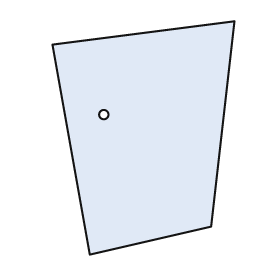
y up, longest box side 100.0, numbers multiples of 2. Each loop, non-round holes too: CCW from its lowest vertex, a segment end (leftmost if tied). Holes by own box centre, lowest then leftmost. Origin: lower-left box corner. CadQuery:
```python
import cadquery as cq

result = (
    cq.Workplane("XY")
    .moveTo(16.0, 0.0)
    .lineTo(68.0, 12.0)
    .lineTo(78.0, 100.0)
    .lineTo(0.0, 90.0)
    .close()
    .moveTo(22.0, 60.0)
    .circle(2.0)
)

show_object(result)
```